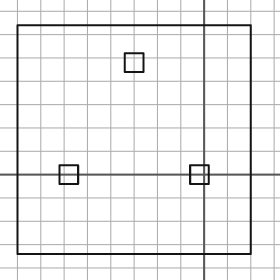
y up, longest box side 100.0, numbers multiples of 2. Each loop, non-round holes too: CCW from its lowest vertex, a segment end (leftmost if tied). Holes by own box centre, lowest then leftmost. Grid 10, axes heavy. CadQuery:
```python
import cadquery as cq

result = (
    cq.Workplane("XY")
    .moveTo(-80.0, -34.0)
    .lineTo(20.0, -34.0)
    .lineTo(20.0, 64.0)
    .lineTo(-80.0, 64.0)
    .close()
    .moveTo(-62.0, -4.0)
    .lineTo(-54.0, -4.0)
    .lineTo(-54.0, 4.0)
    .lineTo(-62.0, 4.0)
    .close()
    .moveTo(-6.0, -4.0)
    .lineTo(2.0, -4.0)
    .lineTo(2.0, 4.0)
    .lineTo(-6.0, 4.0)
    .close()
    .moveTo(-34.0, 44.0)
    .lineTo(-26.0, 44.0)
    .lineTo(-26.0, 52.0)
    .lineTo(-34.0, 52.0)
    .close()
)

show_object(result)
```